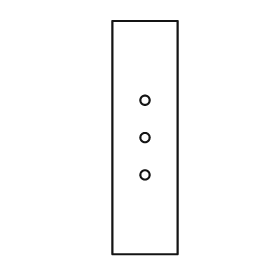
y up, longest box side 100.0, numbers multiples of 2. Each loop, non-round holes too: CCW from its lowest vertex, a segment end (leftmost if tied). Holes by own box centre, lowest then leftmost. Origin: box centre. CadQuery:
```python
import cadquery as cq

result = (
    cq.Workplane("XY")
    .moveTo(-14.0, -50.0)
    .lineTo(14.0, -50.0)
    .lineTo(14.0, 50.0)
    .lineTo(-14.0, 50.0)
    .close()
    .moveTo(0.0, -16.0)
    .circle(2.0)
    .moveTo(0.0, 0.0)
    .circle(2.0)
    .moveTo(0.0, 16.0)
    .circle(2.0)
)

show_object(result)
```